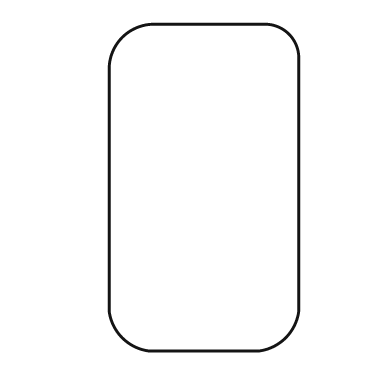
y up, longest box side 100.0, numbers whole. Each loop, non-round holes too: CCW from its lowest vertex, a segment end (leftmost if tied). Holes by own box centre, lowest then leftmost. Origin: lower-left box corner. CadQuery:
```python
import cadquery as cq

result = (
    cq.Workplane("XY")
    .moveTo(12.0, 0.0)
    .lineTo(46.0, 0.0)
    .threePointArc((54.0, 4.0), (58.0, 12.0))
    .lineTo(58.0, 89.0)
    .threePointArc((55.0, 97.0), (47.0, 100.0))
    .lineTo(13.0, 100.0)
    .threePointArc((4.0, 96.0), (0.0, 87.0))
    .lineTo(0.0, 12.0)
    .threePointArc((4.0, 4.0), (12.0, 0.0))
    .close()
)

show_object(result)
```